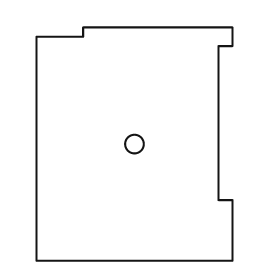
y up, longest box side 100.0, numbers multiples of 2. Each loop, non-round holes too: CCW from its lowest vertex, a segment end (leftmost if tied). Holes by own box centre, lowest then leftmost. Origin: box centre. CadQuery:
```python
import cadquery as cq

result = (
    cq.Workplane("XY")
    .moveTo(-42.0, -50.0)
    .lineTo(42.0, -50.0)
    .lineTo(42.0, -24.0)
    .lineTo(36.0, -24.0)
    .lineTo(36.0, 42.0)
    .lineTo(42.0, 42.0)
    .lineTo(42.0, 50.0)
    .lineTo(-22.0, 50.0)
    .lineTo(-22.0, 46.0)
    .lineTo(-42.0, 46.0)
    .close()
    .moveTo(0.0, 0.0)
    .circle(4.0)
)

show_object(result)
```